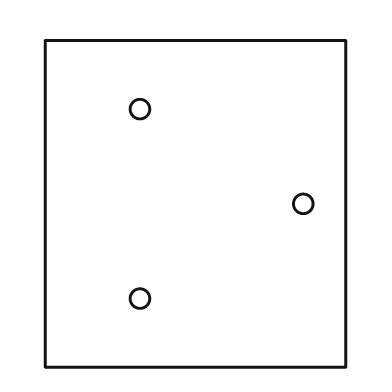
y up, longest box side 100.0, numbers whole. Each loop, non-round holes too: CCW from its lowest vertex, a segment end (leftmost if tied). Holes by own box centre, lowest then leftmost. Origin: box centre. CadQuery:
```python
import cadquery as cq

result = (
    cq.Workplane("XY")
    .moveTo(-46.0, -50.0)
    .lineTo(46.0, -50.0)
    .lineTo(46.0, 50.0)
    .lineTo(-46.0, 50.0)
    .close()
    .moveTo(-17.0, -29.0)
    .circle(3.0)
    .moveTo(33.0, 0.0)
    .circle(3.0)
    .moveTo(-17.0, 29.0)
    .circle(3.0)
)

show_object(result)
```